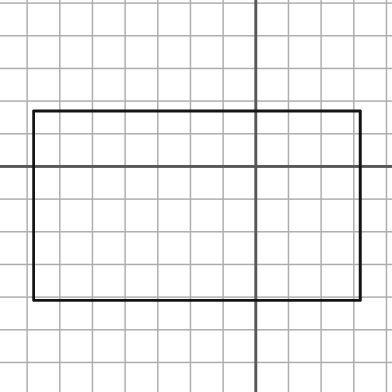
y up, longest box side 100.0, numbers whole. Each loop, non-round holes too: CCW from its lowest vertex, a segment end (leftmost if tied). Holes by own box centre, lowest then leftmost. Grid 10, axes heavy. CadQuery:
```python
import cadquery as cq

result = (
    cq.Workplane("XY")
    .moveTo(-68.0, -41.0)
    .lineTo(32.0, -41.0)
    .lineTo(32.0, 17.0)
    .lineTo(-68.0, 17.0)
    .close()
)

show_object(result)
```